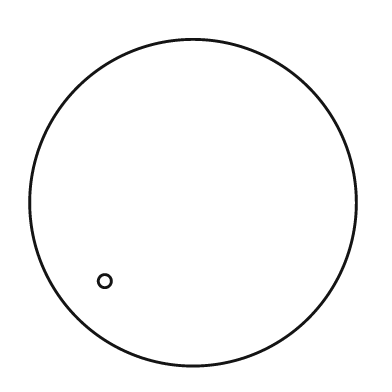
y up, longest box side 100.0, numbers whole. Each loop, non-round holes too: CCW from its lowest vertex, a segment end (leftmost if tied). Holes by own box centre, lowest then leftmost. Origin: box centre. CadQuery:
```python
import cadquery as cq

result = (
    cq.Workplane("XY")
    .moveTo(0.0, 0.0)
    .circle(50.0)
    .moveTo(-27.0, -24.0)
    .circle(2.0)
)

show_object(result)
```